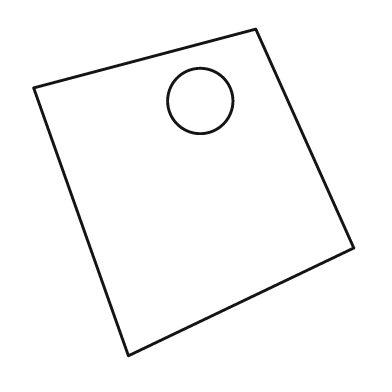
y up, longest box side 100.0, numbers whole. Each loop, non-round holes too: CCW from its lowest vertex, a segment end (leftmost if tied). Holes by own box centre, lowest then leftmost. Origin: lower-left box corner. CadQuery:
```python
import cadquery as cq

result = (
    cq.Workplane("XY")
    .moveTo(29.0, 0.0)
    .lineTo(98.0, 33.0)
    .lineTo(68.0, 100.0)
    .lineTo(0.0, 82.0)
    .close()
    .moveTo(51.0, 78.0)
    .circle(10.0)
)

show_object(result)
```